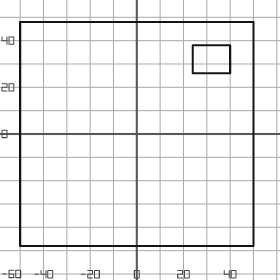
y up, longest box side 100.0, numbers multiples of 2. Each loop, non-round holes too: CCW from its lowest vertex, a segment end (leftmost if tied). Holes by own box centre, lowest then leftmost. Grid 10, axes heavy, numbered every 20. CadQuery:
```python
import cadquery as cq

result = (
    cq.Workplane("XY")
    .moveTo(-50.0, -48.0)
    .lineTo(50.0, -48.0)
    .lineTo(50.0, 48.0)
    .lineTo(-50.0, 48.0)
    .close()
    .moveTo(24.0, 26.0)
    .lineTo(40.0, 26.0)
    .lineTo(40.0, 38.0)
    .lineTo(24.0, 38.0)
    .close()
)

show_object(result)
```